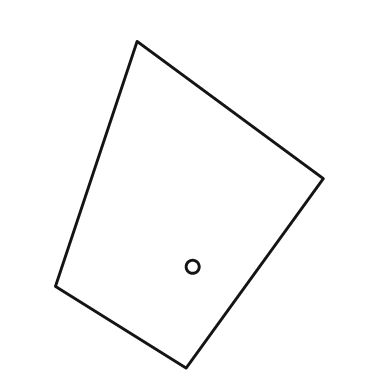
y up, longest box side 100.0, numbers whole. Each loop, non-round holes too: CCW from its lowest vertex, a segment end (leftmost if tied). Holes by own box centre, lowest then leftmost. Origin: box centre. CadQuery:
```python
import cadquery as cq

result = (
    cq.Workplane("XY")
    .moveTo(-1.0, -50.0)
    .lineTo(41.0, 8.0)
    .lineTo(-16.0, 50.0)
    .lineTo(-41.0, -25.0)
    .close()
    .moveTo(1.0, -19.0)
    .circle(2.0)
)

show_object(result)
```